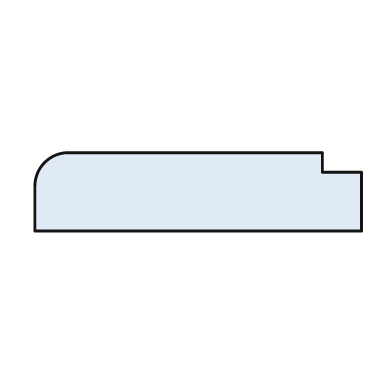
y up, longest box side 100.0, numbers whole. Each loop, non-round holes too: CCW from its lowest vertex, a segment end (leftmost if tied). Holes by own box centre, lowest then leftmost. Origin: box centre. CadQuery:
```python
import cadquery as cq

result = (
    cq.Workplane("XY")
    .moveTo(-50.0, -12.0)
    .lineTo(50.0, -12.0)
    .lineTo(50.0, 6.0)
    .lineTo(38.0, 6.0)
    .lineTo(38.0, 12.0)
    .lineTo(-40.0, 12.0)
    .threePointArc((-47.0, 9.0), (-50.0, 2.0))
    .close()
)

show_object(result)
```